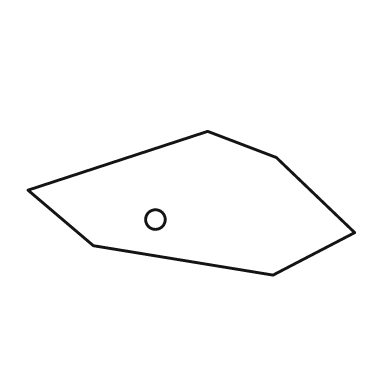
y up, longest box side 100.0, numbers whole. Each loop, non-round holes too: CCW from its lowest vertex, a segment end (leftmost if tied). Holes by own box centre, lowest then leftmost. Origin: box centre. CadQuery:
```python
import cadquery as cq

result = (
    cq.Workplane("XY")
    .moveTo(25.0, -22.0)
    .lineTo(50.0, -9.0)
    .lineTo(26.0, 14.0)
    .lineTo(5.0, 22.0)
    .lineTo(-50.0, 4.0)
    .lineTo(-30.0, -13.0)
    .close()
    .moveTo(-11.0, -5.0)
    .circle(3.0)
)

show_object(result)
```